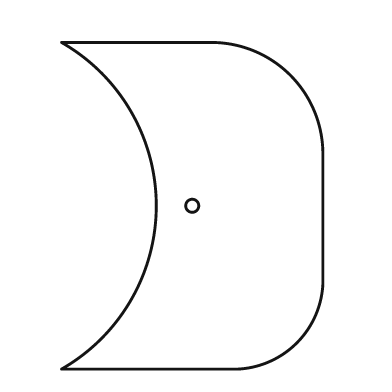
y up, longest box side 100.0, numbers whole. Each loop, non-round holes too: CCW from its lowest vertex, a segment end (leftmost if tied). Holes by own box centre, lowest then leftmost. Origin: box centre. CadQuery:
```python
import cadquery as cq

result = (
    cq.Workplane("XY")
    .moveTo(-40.0, -50.0)
    .lineTo(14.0, -50.0)
    .threePointArc((32.0, -42.0), (40.0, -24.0))
    .lineTo(40.0, 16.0)
    .threePointArc((30.0, 40.0), (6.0, 50.0))
    .lineTo(-40.0, 50.0)
    .threePointArc((-11.0, 0.0), (-40.0, -50.0))
    .close()
    .moveTo(0.0, 0.0)
    .circle(2.0)
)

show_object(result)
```